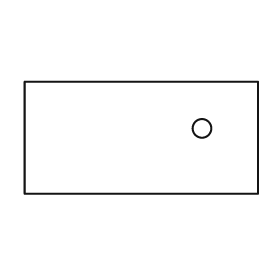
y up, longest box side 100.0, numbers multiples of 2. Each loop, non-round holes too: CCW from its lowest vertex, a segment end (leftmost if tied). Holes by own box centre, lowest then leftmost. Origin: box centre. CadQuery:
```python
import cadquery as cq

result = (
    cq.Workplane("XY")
    .moveTo(-50.0, -24.0)
    .lineTo(50.0, -24.0)
    .lineTo(50.0, 24.0)
    .lineTo(-50.0, 24.0)
    .close()
    .moveTo(26.0, 4.0)
    .circle(4.0)
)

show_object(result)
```